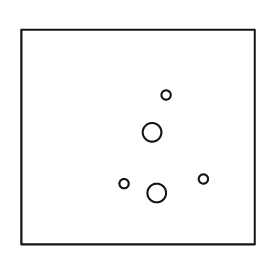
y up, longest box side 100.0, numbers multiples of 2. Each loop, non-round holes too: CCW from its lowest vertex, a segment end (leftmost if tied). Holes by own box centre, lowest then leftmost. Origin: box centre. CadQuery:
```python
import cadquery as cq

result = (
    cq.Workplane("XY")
    .moveTo(-50.0, -46.0)
    .lineTo(50.0, -46.0)
    .lineTo(50.0, 46.0)
    .lineTo(-50.0, 46.0)
    .close()
    .moveTo(8.0, -24.0)
    .circle(4.0)
    .moveTo(-6.0, -20.0)
    .circle(2.0)
    .moveTo(28.0, -18.0)
    .circle(2.0)
    .moveTo(6.0, 2.0)
    .circle(4.0)
    .moveTo(12.0, 18.0)
    .circle(2.0)
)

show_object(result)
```